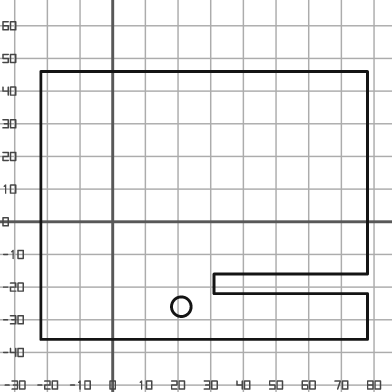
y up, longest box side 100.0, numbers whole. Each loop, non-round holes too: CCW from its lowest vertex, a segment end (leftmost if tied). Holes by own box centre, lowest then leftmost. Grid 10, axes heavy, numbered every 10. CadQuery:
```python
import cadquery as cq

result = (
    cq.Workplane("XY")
    .moveTo(-22.0, -36.0)
    .lineTo(78.0, -36.0)
    .lineTo(78.0, -22.0)
    .lineTo(31.0, -22.0)
    .lineTo(31.0, -16.0)
    .lineTo(78.0, -16.0)
    .lineTo(78.0, 46.0)
    .lineTo(-22.0, 46.0)
    .close()
    .moveTo(21.0, -26.0)
    .circle(3.0)
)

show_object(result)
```